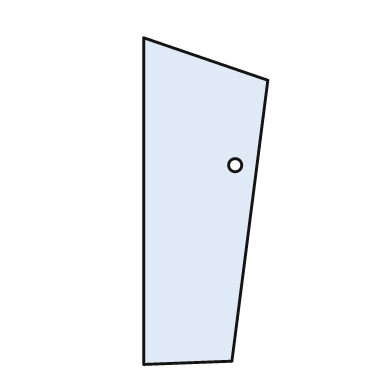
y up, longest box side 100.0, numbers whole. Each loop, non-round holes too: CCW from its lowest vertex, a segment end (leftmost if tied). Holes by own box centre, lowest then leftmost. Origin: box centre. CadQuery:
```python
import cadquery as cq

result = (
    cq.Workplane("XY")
    .moveTo(-19.0, -50.0)
    .lineTo(8.0, -49.0)
    .lineTo(19.0, 37.0)
    .lineTo(-19.0, 50.0)
    .close()
    .moveTo(9.0, 11.0)
    .circle(2.0)
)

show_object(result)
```